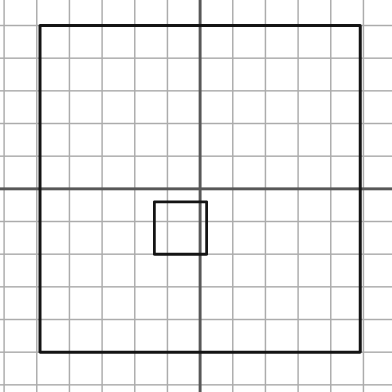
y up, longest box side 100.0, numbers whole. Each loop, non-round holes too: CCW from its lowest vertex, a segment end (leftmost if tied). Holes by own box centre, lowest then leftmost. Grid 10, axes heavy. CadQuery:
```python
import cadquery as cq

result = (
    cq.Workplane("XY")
    .moveTo(-49.0, -50.0)
    .lineTo(49.0, -50.0)
    .lineTo(49.0, 50.0)
    .lineTo(-49.0, 50.0)
    .close()
    .moveTo(-14.0, -20.0)
    .lineTo(2.0, -20.0)
    .lineTo(2.0, -4.0)
    .lineTo(-14.0, -4.0)
    .close()
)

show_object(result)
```